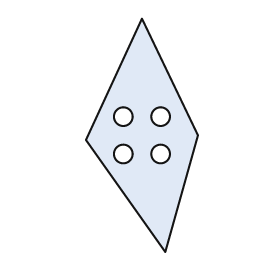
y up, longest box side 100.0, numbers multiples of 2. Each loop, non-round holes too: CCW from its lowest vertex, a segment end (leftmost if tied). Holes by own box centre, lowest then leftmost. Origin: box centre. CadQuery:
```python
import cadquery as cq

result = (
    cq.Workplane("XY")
    .moveTo(10.0, -50.0)
    .lineTo(24.0, 0.0)
    .lineTo(0.0, 50.0)
    .lineTo(-24.0, -2.0)
    .close()
    .moveTo(-8.0, -8.0)
    .circle(4.0)
    .moveTo(8.0, -8.0)
    .circle(4.0)
    .moveTo(-8.0, 8.0)
    .circle(4.0)
    .moveTo(8.0, 8.0)
    .circle(4.0)
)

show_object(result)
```